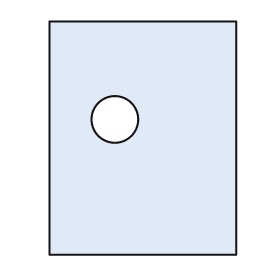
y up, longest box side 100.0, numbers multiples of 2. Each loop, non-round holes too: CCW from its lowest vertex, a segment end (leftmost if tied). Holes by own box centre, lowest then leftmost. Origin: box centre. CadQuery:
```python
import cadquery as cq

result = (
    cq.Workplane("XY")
    .moveTo(-40.0, -50.0)
    .lineTo(40.0, -50.0)
    .lineTo(40.0, 50.0)
    .lineTo(-40.0, 50.0)
    .close()
    .moveTo(-12.0, 8.0)
    .circle(10.0)
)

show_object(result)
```